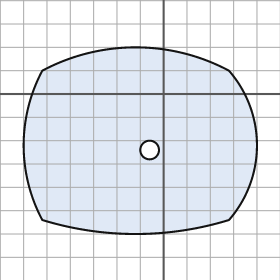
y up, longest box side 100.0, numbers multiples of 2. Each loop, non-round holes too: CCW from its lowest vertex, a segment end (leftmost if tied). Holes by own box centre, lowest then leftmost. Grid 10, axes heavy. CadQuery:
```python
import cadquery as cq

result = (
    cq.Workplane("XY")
    .moveTo(-52.0, -54.0)
    .threePointArc((-12.0, -60.0), (28.0, -54.0))
    .threePointArc((40.0, -22.0), (28.0, 10.0))
    .threePointArc((-12.0, 20.0), (-52.0, 10.0))
    .threePointArc((-60.0, -22.0), (-52.0, -54.0))
    .close()
    .moveTo(-6.0, -24.0)
    .circle(4.0)
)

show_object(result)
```